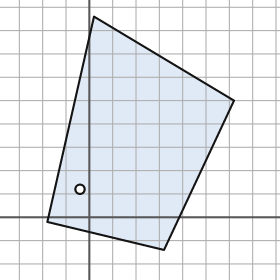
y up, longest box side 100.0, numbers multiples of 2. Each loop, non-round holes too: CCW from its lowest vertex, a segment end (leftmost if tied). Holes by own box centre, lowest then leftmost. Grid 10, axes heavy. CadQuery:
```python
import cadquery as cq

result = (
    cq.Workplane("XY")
    .moveTo(32.0, -14.0)
    .lineTo(62.0, 50.0)
    .lineTo(2.0, 86.0)
    .lineTo(-18.0, -2.0)
    .close()
    .moveTo(-4.0, 12.0)
    .circle(2.0)
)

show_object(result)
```